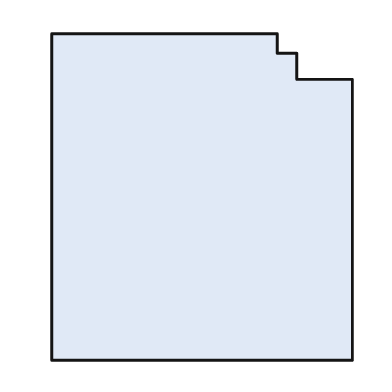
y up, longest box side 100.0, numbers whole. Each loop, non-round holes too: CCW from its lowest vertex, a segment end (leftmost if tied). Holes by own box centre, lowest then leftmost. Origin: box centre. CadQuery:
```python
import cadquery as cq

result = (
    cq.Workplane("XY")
    .moveTo(-46.0, -50.0)
    .lineTo(46.0, -50.0)
    .lineTo(46.0, 36.0)
    .lineTo(29.0, 36.0)
    .lineTo(29.0, 44.0)
    .lineTo(23.0, 44.0)
    .lineTo(23.0, 50.0)
    .lineTo(-46.0, 50.0)
    .close()
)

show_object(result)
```